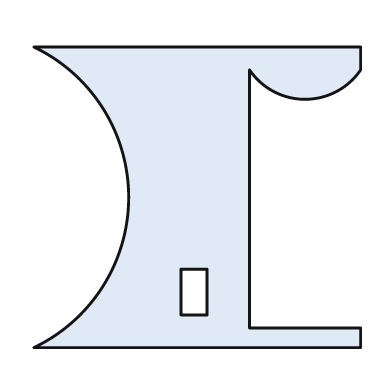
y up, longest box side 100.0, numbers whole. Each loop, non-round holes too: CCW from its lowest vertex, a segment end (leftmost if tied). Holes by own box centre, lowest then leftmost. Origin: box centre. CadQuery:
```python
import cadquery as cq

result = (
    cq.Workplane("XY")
    .moveTo(-50.0, -46.0)
    .lineTo(50.0, -46.0)
    .lineTo(50.0, -40.0)
    .lineTo(16.0, -40.0)
    .lineTo(16.0, 39.0)
    .threePointArc((33.0, 30.0), (50.0, 39.0))
    .lineTo(50.0, 46.0)
    .lineTo(-50.0, 46.0)
    .threePointArc((-21.0, 0.0), (-50.0, -46.0))
    .close()
    .moveTo(-5.0, -36.0)
    .lineTo(3.0, -36.0)
    .lineTo(3.0, -22.0)
    .lineTo(-5.0, -22.0)
    .close()
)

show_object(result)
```